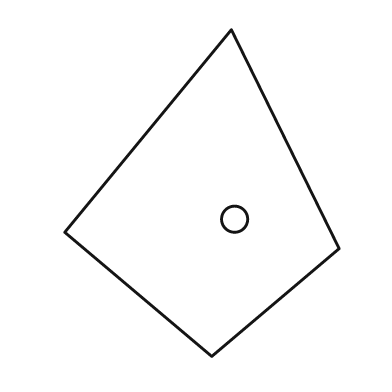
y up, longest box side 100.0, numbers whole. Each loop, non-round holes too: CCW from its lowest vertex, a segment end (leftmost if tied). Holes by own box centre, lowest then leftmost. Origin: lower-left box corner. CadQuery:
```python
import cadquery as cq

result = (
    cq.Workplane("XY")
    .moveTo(45.0, 0.0)
    .lineTo(84.0, 33.0)
    .lineTo(51.0, 100.0)
    .lineTo(0.0, 38.0)
    .close()
    .moveTo(52.0, 42.0)
    .circle(4.0)
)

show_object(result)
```